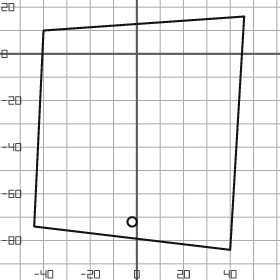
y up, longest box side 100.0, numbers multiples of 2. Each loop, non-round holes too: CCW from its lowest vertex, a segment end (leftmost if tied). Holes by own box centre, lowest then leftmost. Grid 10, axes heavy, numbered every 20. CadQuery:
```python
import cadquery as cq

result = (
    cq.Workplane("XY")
    .moveTo(40.0, -84.0)
    .lineTo(46.0, 16.0)
    .lineTo(-40.0, 10.0)
    .lineTo(-44.0, -74.0)
    .close()
    .moveTo(-2.0, -72.0)
    .circle(2.0)
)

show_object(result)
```